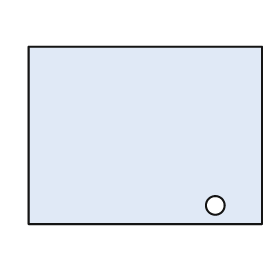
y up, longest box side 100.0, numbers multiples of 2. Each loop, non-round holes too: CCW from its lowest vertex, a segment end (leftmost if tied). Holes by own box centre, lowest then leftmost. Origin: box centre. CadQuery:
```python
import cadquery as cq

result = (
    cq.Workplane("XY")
    .moveTo(-50.0, -38.0)
    .lineTo(50.0, -38.0)
    .lineTo(50.0, 38.0)
    .lineTo(-50.0, 38.0)
    .close()
    .moveTo(30.0, -30.0)
    .circle(4.0)
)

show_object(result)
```